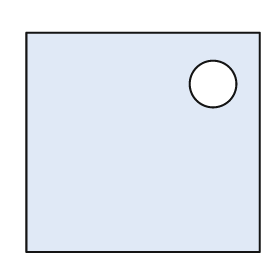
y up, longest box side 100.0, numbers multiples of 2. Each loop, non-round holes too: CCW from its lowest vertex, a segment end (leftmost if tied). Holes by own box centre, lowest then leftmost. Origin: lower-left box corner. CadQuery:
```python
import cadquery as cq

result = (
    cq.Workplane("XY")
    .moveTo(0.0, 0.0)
    .lineTo(100.0, 0.0)
    .lineTo(100.0, 94.0)
    .lineTo(0.0, 94.0)
    .close()
    .moveTo(80.0, 72.0)
    .circle(10.0)
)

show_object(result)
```